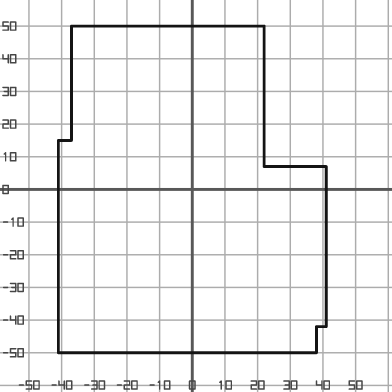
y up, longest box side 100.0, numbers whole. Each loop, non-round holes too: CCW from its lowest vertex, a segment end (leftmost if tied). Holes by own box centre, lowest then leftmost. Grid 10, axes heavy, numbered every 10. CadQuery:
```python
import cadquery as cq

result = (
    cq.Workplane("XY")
    .moveTo(-41.0, -50.0)
    .lineTo(38.0, -50.0)
    .lineTo(38.0, -42.0)
    .lineTo(41.0, -42.0)
    .lineTo(41.0, 7.0)
    .lineTo(22.0, 7.0)
    .lineTo(22.0, 50.0)
    .lineTo(-37.0, 50.0)
    .lineTo(-37.0, 15.0)
    .lineTo(-41.0, 15.0)
    .close()
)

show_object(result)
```